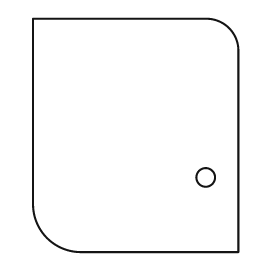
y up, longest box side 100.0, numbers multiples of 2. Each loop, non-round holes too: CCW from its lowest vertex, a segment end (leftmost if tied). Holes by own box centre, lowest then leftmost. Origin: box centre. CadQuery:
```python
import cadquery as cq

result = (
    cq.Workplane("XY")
    .moveTo(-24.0, -50.0)
    .lineTo(44.0, -50.0)
    .lineTo(44.0, 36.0)
    .threePointArc((40.0, 46.0), (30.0, 50.0))
    .lineTo(-44.0, 50.0)
    .lineTo(-44.0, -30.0)
    .threePointArc((-38.0, -44.0), (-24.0, -50.0))
    .close()
    .moveTo(30.0, -18.0)
    .circle(4.0)
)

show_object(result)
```